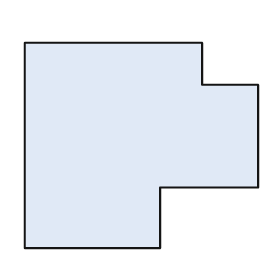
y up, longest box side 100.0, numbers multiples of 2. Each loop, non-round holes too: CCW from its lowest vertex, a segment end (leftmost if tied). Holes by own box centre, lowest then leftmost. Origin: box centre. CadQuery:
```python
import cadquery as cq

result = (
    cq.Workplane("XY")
    .moveTo(-50.0, -44.0)
    .lineTo(8.0, -44.0)
    .lineTo(8.0, -18.0)
    .lineTo(50.0, -18.0)
    .lineTo(50.0, 26.0)
    .lineTo(26.0, 26.0)
    .lineTo(26.0, 44.0)
    .lineTo(-50.0, 44.0)
    .close()
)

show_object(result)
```